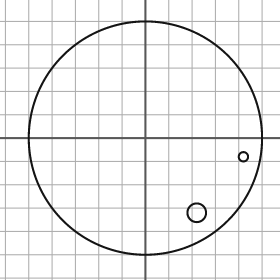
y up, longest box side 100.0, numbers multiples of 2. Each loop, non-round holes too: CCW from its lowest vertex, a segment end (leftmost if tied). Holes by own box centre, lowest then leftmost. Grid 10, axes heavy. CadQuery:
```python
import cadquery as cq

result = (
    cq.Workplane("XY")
    .moveTo(0.0, 0.0)
    .circle(50.0)
    .moveTo(22.0, -32.0)
    .circle(4.0)
    .moveTo(42.0, -8.0)
    .circle(2.0)
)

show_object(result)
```